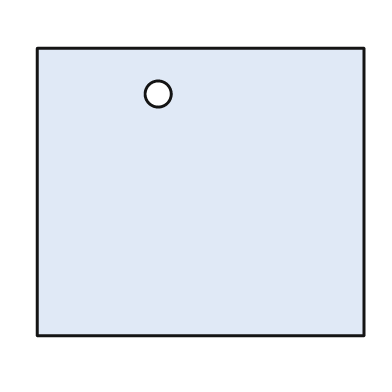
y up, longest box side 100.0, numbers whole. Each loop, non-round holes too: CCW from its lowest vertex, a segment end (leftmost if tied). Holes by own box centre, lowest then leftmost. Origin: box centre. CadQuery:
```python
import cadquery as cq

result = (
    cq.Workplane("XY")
    .moveTo(-50.0, -44.0)
    .lineTo(50.0, -44.0)
    .lineTo(50.0, 44.0)
    .lineTo(-50.0, 44.0)
    .close()
    .moveTo(-13.0, 30.0)
    .circle(4.0)
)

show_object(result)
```